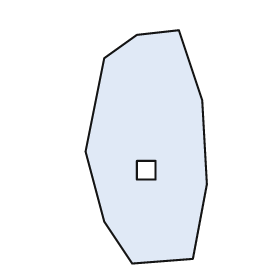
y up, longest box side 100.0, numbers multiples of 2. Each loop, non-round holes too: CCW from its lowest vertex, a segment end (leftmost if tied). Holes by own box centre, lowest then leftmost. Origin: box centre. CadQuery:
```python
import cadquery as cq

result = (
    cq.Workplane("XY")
    .moveTo(-6.0, -50.0)
    .lineTo(20.0, -48.0)
    .lineTo(26.0, -16.0)
    .lineTo(24.0, 20.0)
    .lineTo(14.0, 50.0)
    .lineTo(-4.0, 48.0)
    .lineTo(-18.0, 38.0)
    .lineTo(-26.0, -2.0)
    .lineTo(-18.0, -32.0)
    .close()
    .moveTo(-4.0, -14.0)
    .lineTo(4.0, -14.0)
    .lineTo(4.0, -6.0)
    .lineTo(-4.0, -6.0)
    .close()
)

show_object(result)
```